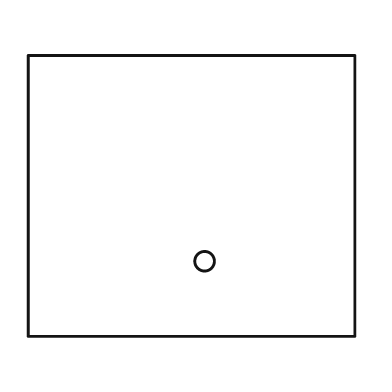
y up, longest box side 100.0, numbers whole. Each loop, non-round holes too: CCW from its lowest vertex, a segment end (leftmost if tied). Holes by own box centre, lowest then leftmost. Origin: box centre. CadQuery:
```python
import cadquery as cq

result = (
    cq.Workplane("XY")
    .moveTo(-50.0, -43.0)
    .lineTo(50.0, -43.0)
    .lineTo(50.0, 43.0)
    .lineTo(-50.0, 43.0)
    .close()
    .moveTo(4.0, -20.0)
    .circle(3.0)
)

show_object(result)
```